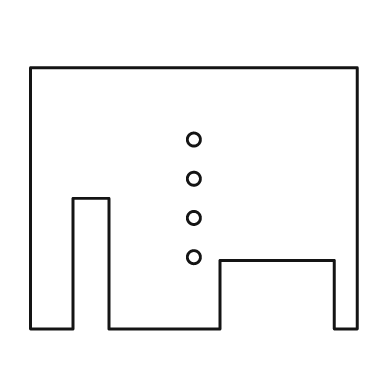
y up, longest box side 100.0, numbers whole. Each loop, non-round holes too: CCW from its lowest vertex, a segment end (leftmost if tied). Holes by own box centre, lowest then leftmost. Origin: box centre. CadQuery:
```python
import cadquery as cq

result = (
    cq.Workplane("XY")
    .moveTo(-50.0, -40.0)
    .lineTo(-37.0, -40.0)
    .lineTo(-37.0, 0.0)
    .lineTo(-26.0, 0.0)
    .lineTo(-26.0, -40.0)
    .lineTo(8.0, -40.0)
    .lineTo(8.0, -19.0)
    .lineTo(43.0, -19.0)
    .lineTo(43.0, -40.0)
    .lineTo(50.0, -40.0)
    .lineTo(50.0, 40.0)
    .lineTo(-50.0, 40.0)
    .close()
    .moveTo(0.0, -18.0)
    .circle(2.0)
    .moveTo(0.0, -6.0)
    .circle(2.0)
    .moveTo(0.0, 6.0)
    .circle(2.0)
    .moveTo(0.0, 18.0)
    .circle(2.0)
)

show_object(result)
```